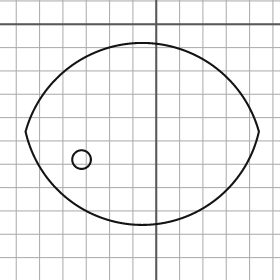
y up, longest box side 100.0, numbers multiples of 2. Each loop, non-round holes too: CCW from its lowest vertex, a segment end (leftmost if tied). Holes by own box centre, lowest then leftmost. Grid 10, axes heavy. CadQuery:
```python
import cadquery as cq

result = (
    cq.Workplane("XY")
    .moveTo(-56.0, -46.0)
    .threePointArc((-6.0, -86.0), (44.0, -46.0))
    .threePointArc((-6.0, -8.0), (-56.0, -46.0))
    .close()
    .moveTo(-32.0, -58.0)
    .circle(4.0)
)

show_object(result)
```